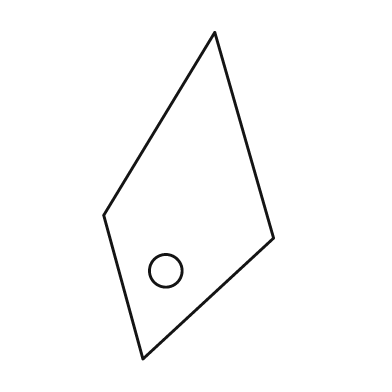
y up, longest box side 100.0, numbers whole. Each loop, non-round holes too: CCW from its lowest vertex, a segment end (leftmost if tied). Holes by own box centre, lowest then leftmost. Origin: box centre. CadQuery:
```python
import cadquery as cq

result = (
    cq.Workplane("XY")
    .moveTo(-14.0, -50.0)
    .lineTo(26.0, -13.0)
    .lineTo(8.0, 50.0)
    .lineTo(-26.0, -6.0)
    .close()
    .moveTo(-7.0, -23.0)
    .circle(5.0)
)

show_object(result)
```